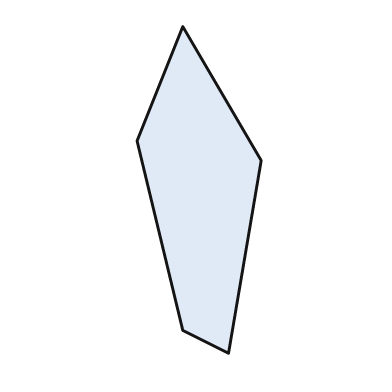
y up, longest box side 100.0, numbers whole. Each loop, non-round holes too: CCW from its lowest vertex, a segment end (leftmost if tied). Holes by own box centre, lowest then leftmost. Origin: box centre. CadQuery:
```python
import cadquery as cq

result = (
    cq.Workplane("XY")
    .moveTo(9.0, -50.0)
    .lineTo(19.0, 9.0)
    .lineTo(-5.0, 50.0)
    .lineTo(-19.0, 15.0)
    .lineTo(-5.0, -43.0)
    .close()
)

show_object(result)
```